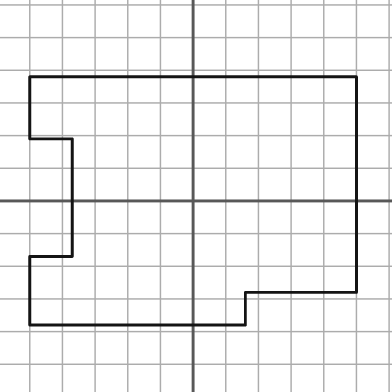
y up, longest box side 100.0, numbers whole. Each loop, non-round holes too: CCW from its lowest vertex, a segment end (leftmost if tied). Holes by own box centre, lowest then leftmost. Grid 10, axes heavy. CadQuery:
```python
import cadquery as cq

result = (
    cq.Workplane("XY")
    .moveTo(-50.0, -38.0)
    .lineTo(16.0, -38.0)
    .lineTo(16.0, -28.0)
    .lineTo(50.0, -28.0)
    .lineTo(50.0, 38.0)
    .lineTo(-50.0, 38.0)
    .lineTo(-50.0, 19.0)
    .lineTo(-37.0, 19.0)
    .lineTo(-37.0, -17.0)
    .lineTo(-50.0, -17.0)
    .close()
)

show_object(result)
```